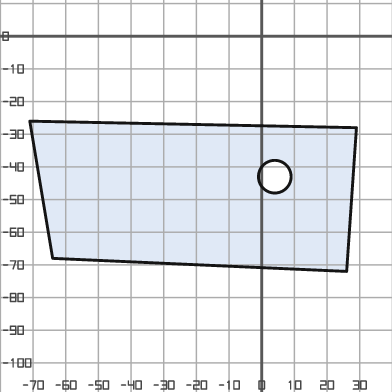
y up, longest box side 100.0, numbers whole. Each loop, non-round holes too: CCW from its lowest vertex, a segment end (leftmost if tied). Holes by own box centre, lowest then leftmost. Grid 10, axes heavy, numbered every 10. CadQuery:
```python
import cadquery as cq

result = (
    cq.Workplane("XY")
    .moveTo(26.0, -72.0)
    .lineTo(29.0, -28.0)
    .lineTo(-71.0, -26.0)
    .lineTo(-64.0, -68.0)
    .close()
    .moveTo(4.0, -43.0)
    .circle(5.0)
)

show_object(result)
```